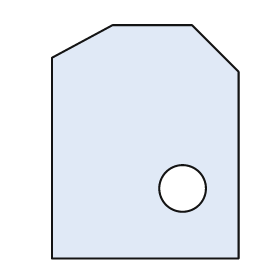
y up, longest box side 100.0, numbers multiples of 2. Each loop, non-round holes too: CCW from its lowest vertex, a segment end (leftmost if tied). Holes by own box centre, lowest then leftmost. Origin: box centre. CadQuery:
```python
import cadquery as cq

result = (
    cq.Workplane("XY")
    .moveTo(-40.0, -50.0)
    .lineTo(40.0, -50.0)
    .lineTo(40.0, 30.0)
    .lineTo(20.0, 50.0)
    .lineTo(-14.0, 50.0)
    .lineTo(-40.0, 36.0)
    .close()
    .moveTo(16.0, -20.0)
    .circle(10.0)
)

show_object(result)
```